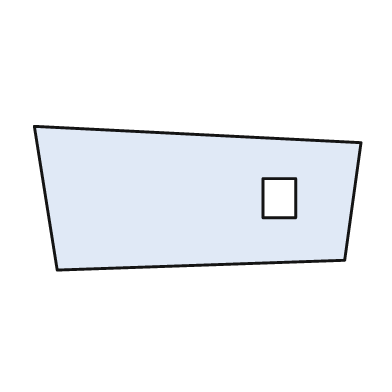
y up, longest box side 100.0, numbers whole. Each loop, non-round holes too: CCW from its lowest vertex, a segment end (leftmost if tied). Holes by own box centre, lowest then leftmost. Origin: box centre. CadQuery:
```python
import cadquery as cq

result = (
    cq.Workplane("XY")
    .moveTo(-43.0, -22.0)
    .lineTo(45.0, -19.0)
    .lineTo(50.0, 17.0)
    .lineTo(-50.0, 22.0)
    .close()
    .moveTo(20.0, -6.0)
    .lineTo(30.0, -6.0)
    .lineTo(30.0, 6.0)
    .lineTo(20.0, 6.0)
    .close()
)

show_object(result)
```